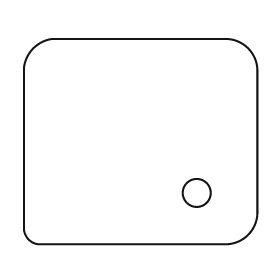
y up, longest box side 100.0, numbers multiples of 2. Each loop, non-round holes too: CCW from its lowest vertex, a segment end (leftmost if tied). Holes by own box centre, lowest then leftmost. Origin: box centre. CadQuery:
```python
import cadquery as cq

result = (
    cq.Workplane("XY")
    .moveTo(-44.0, -44.0)
    .lineTo(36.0, -44.0)
    .threePointArc((46.0, -40.0), (50.0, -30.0))
    .lineTo(50.0, 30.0)
    .threePointArc((46.0, 40.0), (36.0, 44.0))
    .lineTo(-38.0, 44.0)
    .threePointArc((-46.0, 40.0), (-50.0, 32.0))
    .lineTo(-50.0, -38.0)
    .threePointArc((-48.0, -42.0), (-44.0, -44.0))
    .close()
    .moveTo(24.0, -22.0)
    .circle(6.0)
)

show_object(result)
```